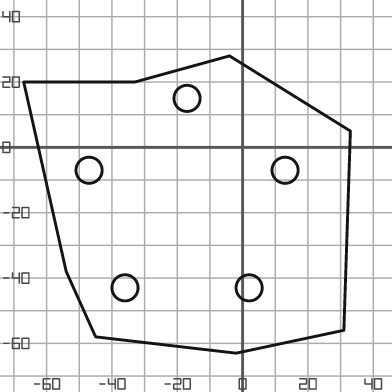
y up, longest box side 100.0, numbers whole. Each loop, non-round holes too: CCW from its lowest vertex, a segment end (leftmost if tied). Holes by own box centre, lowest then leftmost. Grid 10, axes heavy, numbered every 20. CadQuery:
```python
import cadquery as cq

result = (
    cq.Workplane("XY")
    .moveTo(-2.0, -63.0)
    .lineTo(31.0, -56.0)
    .lineTo(33.0, 5.0)
    .lineTo(-4.0, 28.0)
    .lineTo(-33.0, 20.0)
    .lineTo(-67.0, 20.0)
    .lineTo(-54.0, -38.0)
    .lineTo(-45.0, -58.0)
    .close()
    .moveTo(-36.0, -43.0)
    .circle(4.0)
    .moveTo(2.0, -43.0)
    .circle(4.0)
    .moveTo(-47.0, -7.0)
    .circle(4.0)
    .moveTo(13.0, -7.0)
    .circle(4.0)
    .moveTo(-17.0, 15.0)
    .circle(4.0)
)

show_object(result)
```